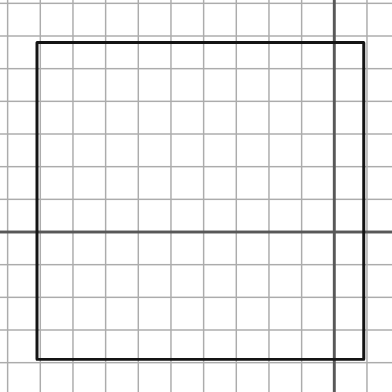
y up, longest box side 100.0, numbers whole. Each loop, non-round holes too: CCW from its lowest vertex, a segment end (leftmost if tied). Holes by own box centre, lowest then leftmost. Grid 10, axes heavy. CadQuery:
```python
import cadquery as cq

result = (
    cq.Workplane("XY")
    .moveTo(-91.0, -39.0)
    .lineTo(9.0, -39.0)
    .lineTo(9.0, 58.0)
    .lineTo(-91.0, 58.0)
    .close()
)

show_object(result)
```